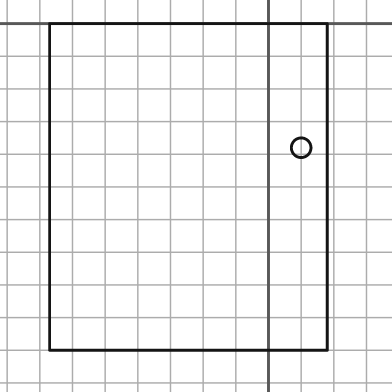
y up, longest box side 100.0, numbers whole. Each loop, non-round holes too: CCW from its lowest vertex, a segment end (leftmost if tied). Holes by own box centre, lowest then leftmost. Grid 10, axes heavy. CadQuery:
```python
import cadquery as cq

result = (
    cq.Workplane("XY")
    .moveTo(-67.0, -100.0)
    .lineTo(18.0, -100.0)
    .lineTo(18.0, 0.0)
    .lineTo(-67.0, 0.0)
    .close()
    .moveTo(10.0, -38.0)
    .circle(3.0)
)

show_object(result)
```